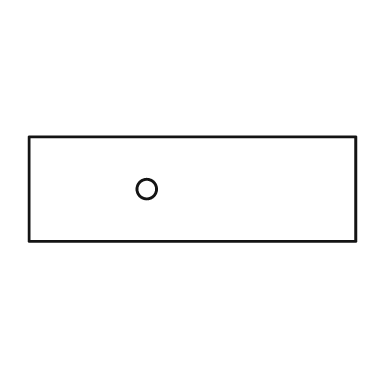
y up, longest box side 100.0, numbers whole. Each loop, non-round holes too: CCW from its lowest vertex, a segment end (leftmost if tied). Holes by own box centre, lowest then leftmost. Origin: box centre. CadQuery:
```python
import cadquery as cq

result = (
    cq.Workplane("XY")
    .moveTo(-50.0, -16.0)
    .lineTo(50.0, -16.0)
    .lineTo(50.0, 16.0)
    .lineTo(-50.0, 16.0)
    .close()
    .moveTo(-14.0, 0.0)
    .circle(3.0)
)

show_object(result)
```